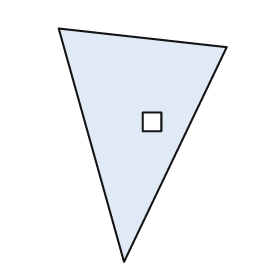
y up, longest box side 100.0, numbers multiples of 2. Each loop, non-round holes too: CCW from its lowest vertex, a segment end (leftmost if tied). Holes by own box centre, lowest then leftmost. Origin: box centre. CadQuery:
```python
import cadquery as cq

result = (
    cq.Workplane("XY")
    .moveTo(-8.0, -50.0)
    .lineTo(36.0, 42.0)
    .lineTo(-36.0, 50.0)
    .close()
    .moveTo(0.0, 6.0)
    .lineTo(8.0, 6.0)
    .lineTo(8.0, 14.0)
    .lineTo(0.0, 14.0)
    .close()
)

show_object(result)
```